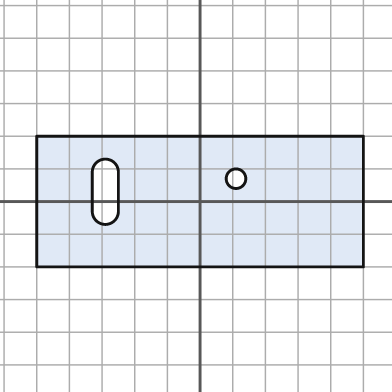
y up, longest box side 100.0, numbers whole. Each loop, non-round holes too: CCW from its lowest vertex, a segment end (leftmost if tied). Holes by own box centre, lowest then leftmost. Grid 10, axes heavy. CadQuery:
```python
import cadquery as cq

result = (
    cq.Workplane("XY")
    .moveTo(-50.0, -20.0)
    .lineTo(50.0, -20.0)
    .lineTo(50.0, 20.0)
    .lineTo(-50.0, 20.0)
    .close()
    .moveTo(-33.0, -3.0)
    .threePointArc((-29.0, -7.0), (-25.0, -3.0))
    .lineTo(-25.0, 9.0)
    .threePointArc((-29.0, 13.0), (-33.0, 9.0))
    .close()
    .moveTo(11.0, 7.0)
    .circle(3.0)
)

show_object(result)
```